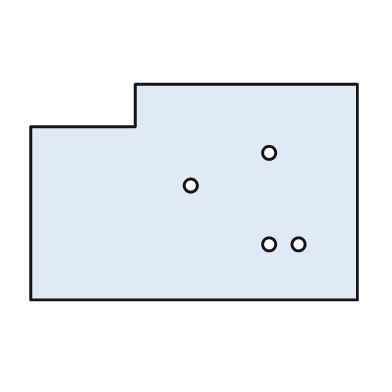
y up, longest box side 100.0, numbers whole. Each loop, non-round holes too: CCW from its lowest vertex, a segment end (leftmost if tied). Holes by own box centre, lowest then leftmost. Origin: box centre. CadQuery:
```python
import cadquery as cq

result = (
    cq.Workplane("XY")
    .moveTo(-50.0, -33.0)
    .lineTo(50.0, -33.0)
    .lineTo(50.0, 33.0)
    .lineTo(-18.0, 33.0)
    .lineTo(-18.0, 20.0)
    .lineTo(-50.0, 20.0)
    .close()
    .moveTo(23.0, -16.0)
    .circle(2.0)
    .moveTo(32.0, -16.0)
    .circle(2.0)
    .moveTo(-1.0, 2.0)
    .circle(2.0)
    .moveTo(23.0, 12.0)
    .circle(2.0)
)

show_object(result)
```